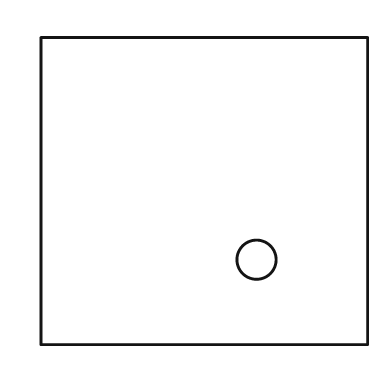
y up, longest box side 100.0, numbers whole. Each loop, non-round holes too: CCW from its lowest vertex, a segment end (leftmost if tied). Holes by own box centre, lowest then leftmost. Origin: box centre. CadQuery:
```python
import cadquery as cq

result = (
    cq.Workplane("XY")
    .moveTo(-50.0, -47.0)
    .lineTo(50.0, -47.0)
    .lineTo(50.0, 47.0)
    .lineTo(-50.0, 47.0)
    .close()
    .moveTo(16.0, -21.0)
    .circle(6.0)
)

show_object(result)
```